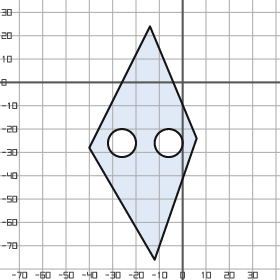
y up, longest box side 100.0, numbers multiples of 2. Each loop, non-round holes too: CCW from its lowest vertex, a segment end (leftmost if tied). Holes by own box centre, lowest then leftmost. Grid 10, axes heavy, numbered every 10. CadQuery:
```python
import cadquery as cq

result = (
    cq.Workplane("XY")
    .moveTo(-12.0, -76.0)
    .lineTo(6.0, -24.0)
    .lineTo(-14.0, 24.0)
    .lineTo(-40.0, -28.0)
    .close()
    .moveTo(-26.0, -26.0)
    .circle(6.0)
    .moveTo(-6.0, -26.0)
    .circle(6.0)
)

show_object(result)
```